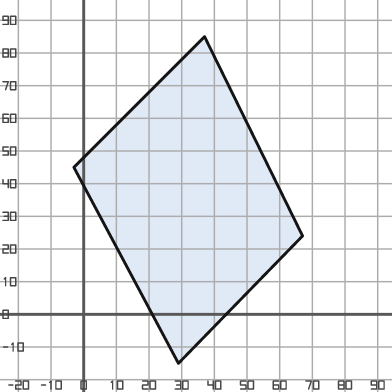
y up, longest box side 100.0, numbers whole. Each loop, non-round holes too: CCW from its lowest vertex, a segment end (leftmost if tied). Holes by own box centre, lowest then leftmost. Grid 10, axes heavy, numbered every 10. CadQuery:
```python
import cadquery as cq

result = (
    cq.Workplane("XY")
    .moveTo(29.0, -15.0)
    .lineTo(67.0, 24.0)
    .lineTo(37.0, 85.0)
    .lineTo(-3.0, 45.0)
    .close()
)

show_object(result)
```